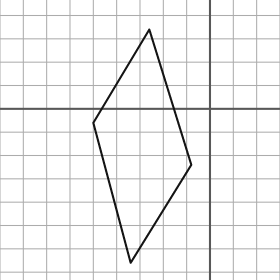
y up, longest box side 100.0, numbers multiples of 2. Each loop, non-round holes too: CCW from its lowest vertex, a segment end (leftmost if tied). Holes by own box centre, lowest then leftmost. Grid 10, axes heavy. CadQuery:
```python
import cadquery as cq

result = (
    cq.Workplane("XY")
    .moveTo(-34.0, -66.0)
    .lineTo(-8.0, -24.0)
    .lineTo(-26.0, 34.0)
    .lineTo(-50.0, -6.0)
    .close()
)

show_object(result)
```